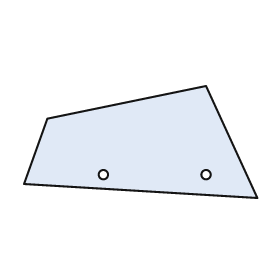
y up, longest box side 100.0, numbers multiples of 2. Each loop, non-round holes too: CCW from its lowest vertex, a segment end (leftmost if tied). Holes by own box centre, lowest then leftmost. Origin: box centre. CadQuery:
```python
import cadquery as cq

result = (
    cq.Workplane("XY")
    .moveTo(50.0, -24.0)
    .lineTo(28.0, 24.0)
    .lineTo(-40.0, 10.0)
    .lineTo(-50.0, -18.0)
    .close()
    .moveTo(-16.0, -14.0)
    .circle(2.0)
    .moveTo(28.0, -14.0)
    .circle(2.0)
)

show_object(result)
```